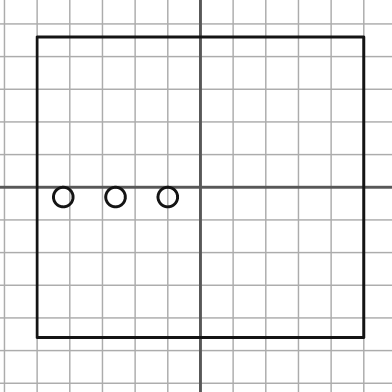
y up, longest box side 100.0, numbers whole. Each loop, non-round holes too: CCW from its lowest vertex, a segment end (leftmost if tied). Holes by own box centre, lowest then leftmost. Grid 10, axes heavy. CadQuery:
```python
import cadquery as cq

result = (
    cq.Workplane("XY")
    .moveTo(-50.0, -46.0)
    .lineTo(50.0, -46.0)
    .lineTo(50.0, 46.0)
    .lineTo(-50.0, 46.0)
    .close()
    .moveTo(-42.0, -3.0)
    .circle(3.0)
    .moveTo(-26.0, -3.0)
    .circle(3.0)
    .moveTo(-10.0, -3.0)
    .circle(3.0)
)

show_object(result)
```